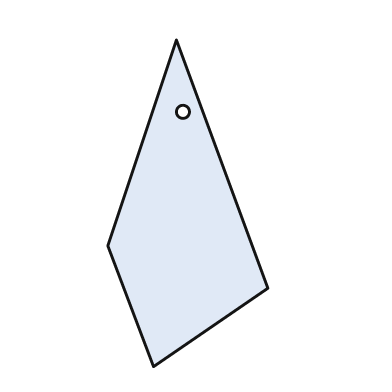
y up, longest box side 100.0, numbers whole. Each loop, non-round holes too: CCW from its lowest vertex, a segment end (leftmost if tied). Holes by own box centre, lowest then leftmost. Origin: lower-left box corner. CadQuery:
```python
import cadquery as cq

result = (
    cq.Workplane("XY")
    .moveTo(14.0, 0.0)
    .lineTo(49.0, 24.0)
    .lineTo(21.0, 100.0)
    .lineTo(0.0, 37.0)
    .close()
    .moveTo(23.0, 78.0)
    .circle(2.0)
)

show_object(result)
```